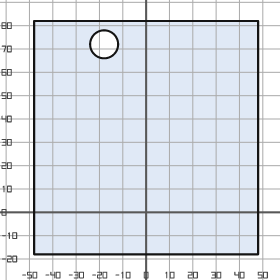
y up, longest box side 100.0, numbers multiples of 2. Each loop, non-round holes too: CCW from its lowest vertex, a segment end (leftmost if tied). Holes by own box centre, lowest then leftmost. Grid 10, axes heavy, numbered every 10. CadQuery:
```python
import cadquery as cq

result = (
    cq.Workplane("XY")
    .moveTo(-48.0, -18.0)
    .lineTo(48.0, -18.0)
    .lineTo(48.0, 82.0)
    .lineTo(-48.0, 82.0)
    .close()
    .moveTo(-18.0, 72.0)
    .circle(6.0)
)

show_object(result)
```